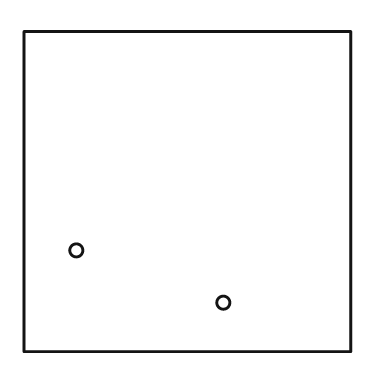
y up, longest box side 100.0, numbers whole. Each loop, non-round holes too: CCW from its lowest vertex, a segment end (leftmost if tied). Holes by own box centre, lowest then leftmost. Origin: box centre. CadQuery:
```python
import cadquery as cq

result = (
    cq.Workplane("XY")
    .moveTo(-50.0, -49.0)
    .lineTo(50.0, -49.0)
    .lineTo(50.0, 49.0)
    .lineTo(-50.0, 49.0)
    .close()
    .moveTo(11.0, -34.0)
    .circle(2.0)
    .moveTo(-34.0, -18.0)
    .circle(2.0)
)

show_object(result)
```